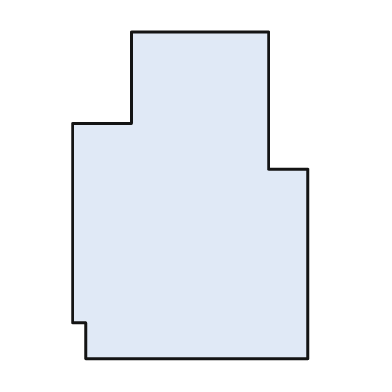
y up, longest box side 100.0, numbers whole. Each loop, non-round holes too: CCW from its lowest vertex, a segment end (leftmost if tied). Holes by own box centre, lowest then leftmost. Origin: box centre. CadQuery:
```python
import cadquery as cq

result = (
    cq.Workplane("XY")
    .moveTo(-32.0, -50.0)
    .lineTo(36.0, -50.0)
    .lineTo(36.0, 8.0)
    .lineTo(24.0, 8.0)
    .lineTo(24.0, 50.0)
    .lineTo(-18.0, 50.0)
    .lineTo(-18.0, 22.0)
    .lineTo(-36.0, 22.0)
    .lineTo(-36.0, -39.0)
    .lineTo(-32.0, -39.0)
    .close()
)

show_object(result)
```